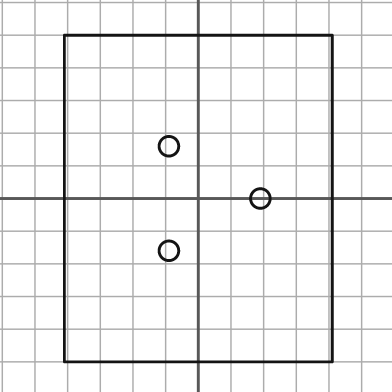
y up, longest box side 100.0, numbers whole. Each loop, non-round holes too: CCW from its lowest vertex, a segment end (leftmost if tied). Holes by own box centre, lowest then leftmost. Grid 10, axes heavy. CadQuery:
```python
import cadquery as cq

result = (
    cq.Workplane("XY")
    .moveTo(-41.0, -50.0)
    .lineTo(41.0, -50.0)
    .lineTo(41.0, 50.0)
    .lineTo(-41.0, 50.0)
    .close()
    .moveTo(-9.0, -16.0)
    .circle(3.0)
    .moveTo(19.0, 0.0)
    .circle(3.0)
    .moveTo(-9.0, 16.0)
    .circle(3.0)
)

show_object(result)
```